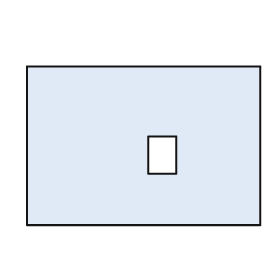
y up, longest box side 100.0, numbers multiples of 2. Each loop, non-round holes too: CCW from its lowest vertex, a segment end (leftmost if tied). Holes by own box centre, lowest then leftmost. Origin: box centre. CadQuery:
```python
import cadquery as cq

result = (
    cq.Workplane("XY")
    .moveTo(-50.0, -34.0)
    .lineTo(50.0, -34.0)
    .lineTo(50.0, 34.0)
    .lineTo(-50.0, 34.0)
    .close()
    .moveTo(2.0, -12.0)
    .lineTo(14.0, -12.0)
    .lineTo(14.0, 4.0)
    .lineTo(2.0, 4.0)
    .close()
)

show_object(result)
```